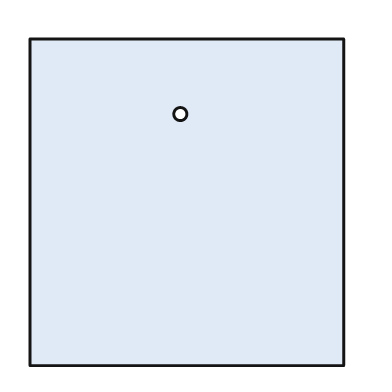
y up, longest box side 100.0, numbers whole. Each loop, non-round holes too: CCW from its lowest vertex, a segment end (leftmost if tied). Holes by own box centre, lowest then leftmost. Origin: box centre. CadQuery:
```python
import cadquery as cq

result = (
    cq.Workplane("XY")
    .moveTo(-48.0, -50.0)
    .lineTo(48.0, -50.0)
    .lineTo(48.0, 50.0)
    .lineTo(-48.0, 50.0)
    .close()
    .moveTo(-2.0, 27.0)
    .circle(2.0)
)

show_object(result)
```